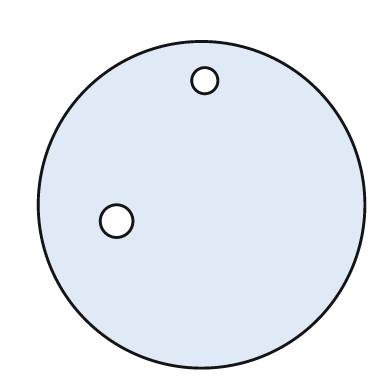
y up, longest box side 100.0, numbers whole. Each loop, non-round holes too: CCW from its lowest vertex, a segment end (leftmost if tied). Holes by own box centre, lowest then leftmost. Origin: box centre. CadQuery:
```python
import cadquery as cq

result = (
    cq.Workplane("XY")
    .moveTo(0.0, 0.0)
    .circle(50.0)
    .moveTo(-26.0, -5.0)
    .circle(5.0)
    .moveTo(1.0, 38.0)
    .circle(4.0)
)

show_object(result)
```